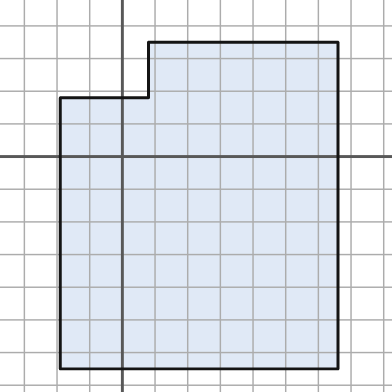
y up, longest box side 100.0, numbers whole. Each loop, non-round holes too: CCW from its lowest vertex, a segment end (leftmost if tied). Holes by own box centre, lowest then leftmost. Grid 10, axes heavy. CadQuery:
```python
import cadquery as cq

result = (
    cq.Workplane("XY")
    .moveTo(-19.0, -65.0)
    .lineTo(66.0, -65.0)
    .lineTo(66.0, 35.0)
    .lineTo(8.0, 35.0)
    .lineTo(8.0, 18.0)
    .lineTo(-19.0, 18.0)
    .close()
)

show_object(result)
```